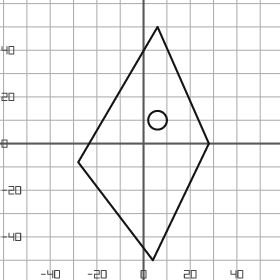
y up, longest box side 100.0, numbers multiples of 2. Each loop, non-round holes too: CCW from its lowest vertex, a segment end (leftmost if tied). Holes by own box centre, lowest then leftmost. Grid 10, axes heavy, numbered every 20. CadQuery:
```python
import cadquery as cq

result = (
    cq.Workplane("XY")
    .moveTo(4.0, -50.0)
    .lineTo(28.0, 0.0)
    .lineTo(6.0, 50.0)
    .lineTo(-28.0, -8.0)
    .close()
    .moveTo(6.0, 10.0)
    .circle(4.0)
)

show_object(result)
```